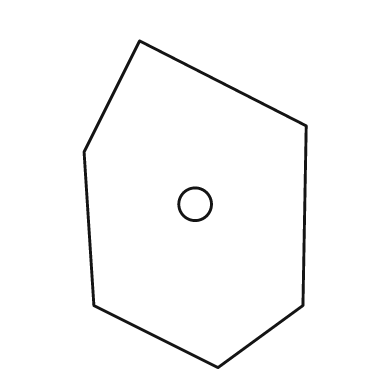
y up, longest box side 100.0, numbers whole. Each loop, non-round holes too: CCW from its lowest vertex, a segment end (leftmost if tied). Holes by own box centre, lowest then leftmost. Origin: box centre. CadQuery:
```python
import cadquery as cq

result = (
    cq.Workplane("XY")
    .moveTo(7.0, -50.0)
    .lineTo(33.0, -31.0)
    .lineTo(34.0, 24.0)
    .lineTo(-17.0, 50.0)
    .lineTo(-34.0, 16.0)
    .lineTo(-31.0, -31.0)
    .close()
    .moveTo(0.0, 0.0)
    .circle(5.0)
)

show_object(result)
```